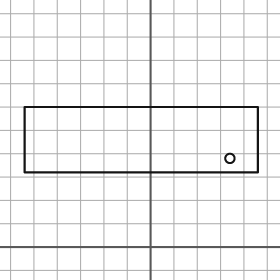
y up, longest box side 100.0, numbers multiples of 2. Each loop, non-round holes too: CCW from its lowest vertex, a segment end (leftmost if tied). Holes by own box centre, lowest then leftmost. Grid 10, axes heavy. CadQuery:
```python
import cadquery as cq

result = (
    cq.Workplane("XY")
    .moveTo(-54.0, 32.0)
    .lineTo(46.0, 32.0)
    .lineTo(46.0, 60.0)
    .lineTo(-54.0, 60.0)
    .close()
    .moveTo(34.0, 38.0)
    .circle(2.0)
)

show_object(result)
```